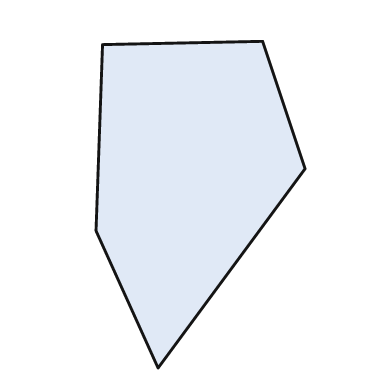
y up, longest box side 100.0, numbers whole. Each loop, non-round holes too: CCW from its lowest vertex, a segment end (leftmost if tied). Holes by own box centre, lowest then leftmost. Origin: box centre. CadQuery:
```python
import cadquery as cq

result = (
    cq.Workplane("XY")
    .moveTo(-13.0, -50.0)
    .lineTo(32.0, 11.0)
    .lineTo(19.0, 50.0)
    .lineTo(-30.0, 49.0)
    .lineTo(-32.0, -8.0)
    .close()
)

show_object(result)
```